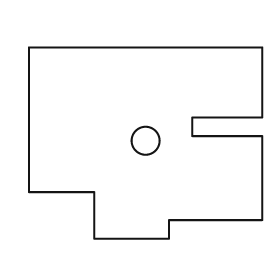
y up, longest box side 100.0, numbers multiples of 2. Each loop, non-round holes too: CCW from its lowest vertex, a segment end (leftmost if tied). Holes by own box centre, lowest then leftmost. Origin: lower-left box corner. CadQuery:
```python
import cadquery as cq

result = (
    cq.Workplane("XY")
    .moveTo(28.0, 0.0)
    .lineTo(60.0, 0.0)
    .lineTo(60.0, 8.0)
    .lineTo(100.0, 8.0)
    .lineTo(100.0, 44.0)
    .lineTo(70.0, 44.0)
    .lineTo(70.0, 52.0)
    .lineTo(100.0, 52.0)
    .lineTo(100.0, 82.0)
    .lineTo(0.0, 82.0)
    .lineTo(0.0, 20.0)
    .lineTo(28.0, 20.0)
    .close()
    .moveTo(50.0, 42.0)
    .circle(6.0)
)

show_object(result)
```